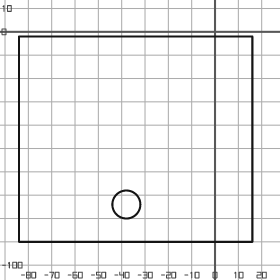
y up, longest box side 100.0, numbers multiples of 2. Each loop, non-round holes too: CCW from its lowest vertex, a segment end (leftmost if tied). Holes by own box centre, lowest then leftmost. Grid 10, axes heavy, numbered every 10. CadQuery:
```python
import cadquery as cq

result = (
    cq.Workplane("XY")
    .moveTo(-84.0, -90.0)
    .lineTo(16.0, -90.0)
    .lineTo(16.0, -2.0)
    .lineTo(-84.0, -2.0)
    .close()
    .moveTo(-38.0, -74.0)
    .circle(6.0)
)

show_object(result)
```